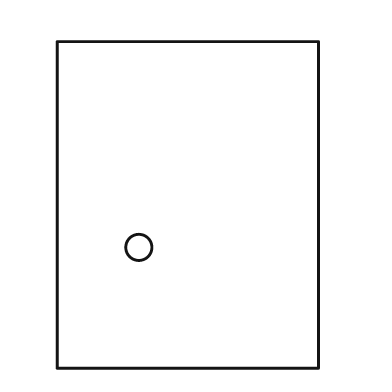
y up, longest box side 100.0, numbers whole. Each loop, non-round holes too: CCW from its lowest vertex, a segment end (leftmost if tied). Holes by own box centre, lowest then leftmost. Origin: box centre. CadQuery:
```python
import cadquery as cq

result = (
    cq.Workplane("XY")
    .moveTo(-40.0, -50.0)
    .lineTo(40.0, -50.0)
    .lineTo(40.0, 50.0)
    .lineTo(-40.0, 50.0)
    .close()
    .moveTo(-15.0, -13.0)
    .circle(4.0)
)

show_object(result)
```